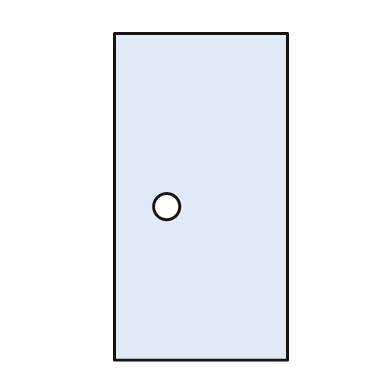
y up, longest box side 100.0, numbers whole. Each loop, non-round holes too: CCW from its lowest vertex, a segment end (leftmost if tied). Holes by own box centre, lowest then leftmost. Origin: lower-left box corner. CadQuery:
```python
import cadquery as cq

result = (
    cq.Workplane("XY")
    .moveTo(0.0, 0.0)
    .lineTo(53.0, 0.0)
    .lineTo(53.0, 100.0)
    .lineTo(0.0, 100.0)
    .close()
    .moveTo(16.0, 47.0)
    .circle(4.0)
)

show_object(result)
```